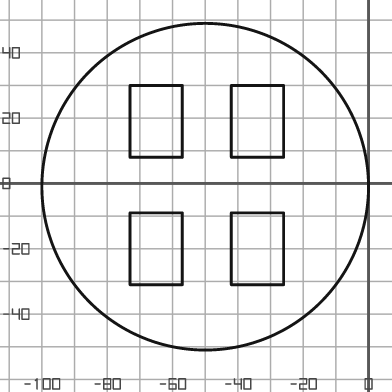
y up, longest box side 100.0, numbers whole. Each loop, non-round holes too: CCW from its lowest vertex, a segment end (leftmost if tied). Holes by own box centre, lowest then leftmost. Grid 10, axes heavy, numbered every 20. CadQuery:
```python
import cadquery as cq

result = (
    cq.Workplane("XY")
    .moveTo(-50.0, -1.0)
    .circle(50.0)
    .moveTo(-73.0, -31.0)
    .lineTo(-57.0, -31.0)
    .lineTo(-57.0, -9.0)
    .lineTo(-73.0, -9.0)
    .close()
    .moveTo(-42.0, -31.0)
    .lineTo(-26.0, -31.0)
    .lineTo(-26.0, -9.0)
    .lineTo(-42.0, -9.0)
    .close()
    .moveTo(-73.0, 8.0)
    .lineTo(-57.0, 8.0)
    .lineTo(-57.0, 30.0)
    .lineTo(-73.0, 30.0)
    .close()
    .moveTo(-42.0, 8.0)
    .lineTo(-26.0, 8.0)
    .lineTo(-26.0, 30.0)
    .lineTo(-42.0, 30.0)
    .close()
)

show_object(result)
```